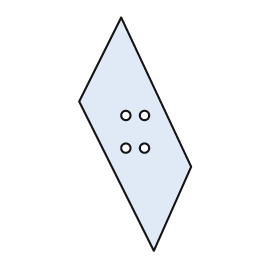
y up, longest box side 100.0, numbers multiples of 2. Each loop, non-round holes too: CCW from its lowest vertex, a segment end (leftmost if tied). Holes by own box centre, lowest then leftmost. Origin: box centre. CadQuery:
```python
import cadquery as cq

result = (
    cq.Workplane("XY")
    .moveTo(8.0, -50.0)
    .lineTo(24.0, -14.0)
    .lineTo(-6.0, 50.0)
    .lineTo(-24.0, 14.0)
    .close()
    .moveTo(-4.0, -6.0)
    .circle(2.0)
    .moveTo(4.0, -6.0)
    .circle(2.0)
    .moveTo(-4.0, 8.0)
    .circle(2.0)
    .moveTo(4.0, 8.0)
    .circle(2.0)
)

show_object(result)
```